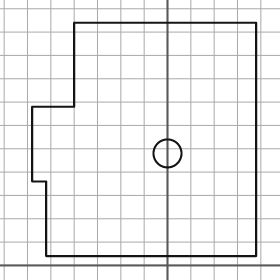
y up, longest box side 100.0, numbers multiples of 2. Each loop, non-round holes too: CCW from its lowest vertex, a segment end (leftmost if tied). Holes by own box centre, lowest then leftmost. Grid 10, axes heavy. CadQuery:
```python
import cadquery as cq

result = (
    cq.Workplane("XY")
    .moveTo(-52.0, 4.0)
    .lineTo(38.0, 4.0)
    .lineTo(38.0, 104.0)
    .lineTo(-40.0, 104.0)
    .lineTo(-40.0, 68.0)
    .lineTo(-58.0, 68.0)
    .lineTo(-58.0, 36.0)
    .lineTo(-52.0, 36.0)
    .close()
    .moveTo(0.0, 48.0)
    .circle(6.0)
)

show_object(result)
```